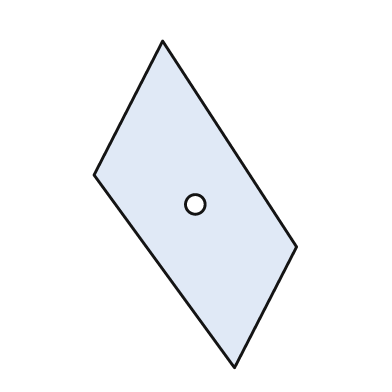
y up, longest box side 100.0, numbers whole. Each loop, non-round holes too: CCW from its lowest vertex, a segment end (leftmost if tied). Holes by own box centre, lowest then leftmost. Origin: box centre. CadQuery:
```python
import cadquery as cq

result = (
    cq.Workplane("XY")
    .moveTo(12.0, -50.0)
    .lineTo(31.0, -13.0)
    .lineTo(-10.0, 50.0)
    .lineTo(-31.0, 9.0)
    .close()
    .moveTo(0.0, 0.0)
    .circle(3.0)
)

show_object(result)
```